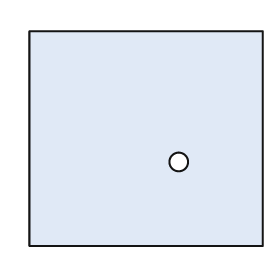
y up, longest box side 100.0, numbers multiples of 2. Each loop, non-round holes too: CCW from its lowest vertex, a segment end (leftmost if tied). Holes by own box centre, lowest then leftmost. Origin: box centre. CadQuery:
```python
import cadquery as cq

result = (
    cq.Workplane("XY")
    .moveTo(-50.0, -46.0)
    .lineTo(50.0, -46.0)
    .lineTo(50.0, 46.0)
    .lineTo(-50.0, 46.0)
    .close()
    .moveTo(14.0, -10.0)
    .circle(4.0)
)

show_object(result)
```